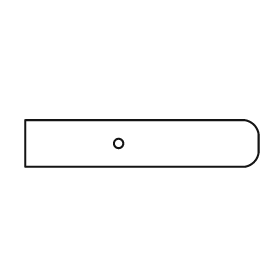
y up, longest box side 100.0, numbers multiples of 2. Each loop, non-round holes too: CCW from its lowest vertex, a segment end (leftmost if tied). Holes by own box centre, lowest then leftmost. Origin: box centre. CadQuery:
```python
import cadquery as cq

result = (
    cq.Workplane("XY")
    .moveTo(-50.0, -10.0)
    .lineTo(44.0, -10.0)
    .threePointArc((48.0, -8.0), (50.0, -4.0))
    .lineTo(50.0, 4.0)
    .threePointArc((48.0, 8.0), (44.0, 10.0))
    .lineTo(-50.0, 10.0)
    .close()
    .moveTo(-10.0, 0.0)
    .circle(2.0)
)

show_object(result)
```